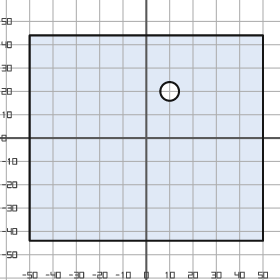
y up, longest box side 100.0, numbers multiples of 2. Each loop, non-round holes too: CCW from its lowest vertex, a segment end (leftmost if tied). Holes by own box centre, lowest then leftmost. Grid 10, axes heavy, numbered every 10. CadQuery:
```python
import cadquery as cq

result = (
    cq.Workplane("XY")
    .moveTo(-50.0, -44.0)
    .lineTo(50.0, -44.0)
    .lineTo(50.0, 44.0)
    .lineTo(-50.0, 44.0)
    .close()
    .moveTo(10.0, 20.0)
    .circle(4.0)
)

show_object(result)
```